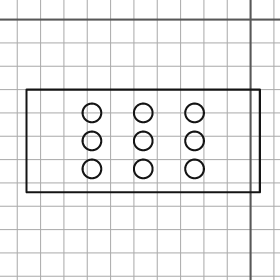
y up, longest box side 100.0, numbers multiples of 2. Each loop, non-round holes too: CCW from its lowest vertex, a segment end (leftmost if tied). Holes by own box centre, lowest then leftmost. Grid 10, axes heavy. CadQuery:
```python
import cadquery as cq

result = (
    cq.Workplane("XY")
    .moveTo(-96.0, -74.0)
    .lineTo(4.0, -74.0)
    .lineTo(4.0, -30.0)
    .lineTo(-96.0, -30.0)
    .close()
    .moveTo(-68.0, -64.0)
    .circle(4.0)
    .moveTo(-46.0, -64.0)
    .circle(4.0)
    .moveTo(-24.0, -64.0)
    .circle(4.0)
    .moveTo(-68.0, -52.0)
    .circle(4.0)
    .moveTo(-46.0, -52.0)
    .circle(4.0)
    .moveTo(-24.0, -52.0)
    .circle(4.0)
    .moveTo(-68.0, -40.0)
    .circle(4.0)
    .moveTo(-46.0, -40.0)
    .circle(4.0)
    .moveTo(-24.0, -40.0)
    .circle(4.0)
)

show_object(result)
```